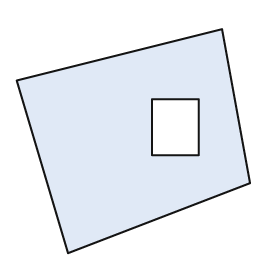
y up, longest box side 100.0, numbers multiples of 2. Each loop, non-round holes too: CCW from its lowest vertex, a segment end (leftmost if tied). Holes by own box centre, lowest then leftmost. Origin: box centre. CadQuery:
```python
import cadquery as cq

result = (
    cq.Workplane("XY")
    .moveTo(-28.0, -48.0)
    .lineTo(50.0, -18.0)
    .lineTo(38.0, 48.0)
    .lineTo(-50.0, 26.0)
    .close()
    .moveTo(8.0, -6.0)
    .lineTo(28.0, -6.0)
    .lineTo(28.0, 18.0)
    .lineTo(8.0, 18.0)
    .close()
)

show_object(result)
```